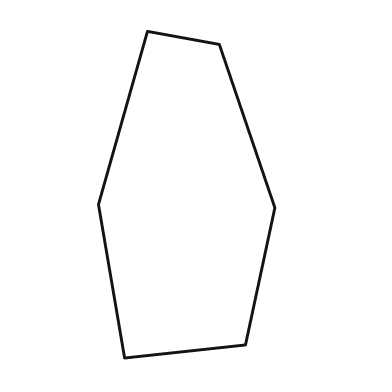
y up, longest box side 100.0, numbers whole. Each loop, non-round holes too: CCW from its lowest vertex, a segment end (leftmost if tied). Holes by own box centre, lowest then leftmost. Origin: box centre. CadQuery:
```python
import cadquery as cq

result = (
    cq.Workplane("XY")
    .moveTo(-19.0, -50.0)
    .lineTo(18.0, -46.0)
    .lineTo(27.0, -4.0)
    .lineTo(10.0, 46.0)
    .lineTo(-12.0, 50.0)
    .lineTo(-27.0, -3.0)
    .close()
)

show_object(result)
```